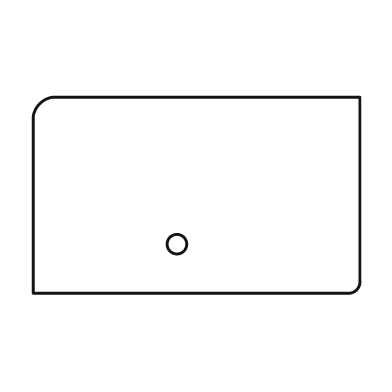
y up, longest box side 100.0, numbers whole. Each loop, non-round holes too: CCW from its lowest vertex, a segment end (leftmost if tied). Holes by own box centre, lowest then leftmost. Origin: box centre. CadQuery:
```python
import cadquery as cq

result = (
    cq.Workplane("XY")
    .moveTo(-50.0, -30.0)
    .lineTo(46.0, -30.0)
    .threePointArc((49.0, -29.0), (50.0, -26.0))
    .lineTo(50.0, 30.0)
    .lineTo(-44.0, 30.0)
    .threePointArc((-48.0, 28.0), (-50.0, 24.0))
    .close()
    .moveTo(-6.0, -15.0)
    .circle(3.0)
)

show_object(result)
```